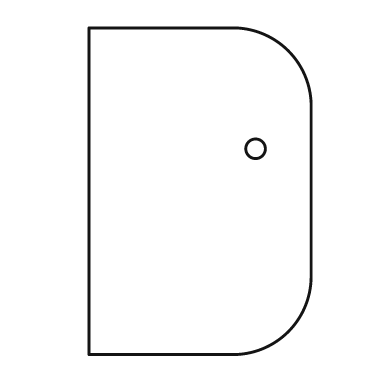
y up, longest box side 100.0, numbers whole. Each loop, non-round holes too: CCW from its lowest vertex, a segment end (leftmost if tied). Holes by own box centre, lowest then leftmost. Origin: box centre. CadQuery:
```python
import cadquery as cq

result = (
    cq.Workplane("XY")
    .moveTo(-34.0, -50.0)
    .lineTo(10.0, -50.0)
    .threePointArc((27.0, -43.0), (34.0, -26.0))
    .lineTo(34.0, 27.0)
    .threePointArc((27.0, 43.0), (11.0, 50.0))
    .lineTo(-34.0, 50.0)
    .close()
    .moveTo(17.0, 13.0)
    .circle(3.0)
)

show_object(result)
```